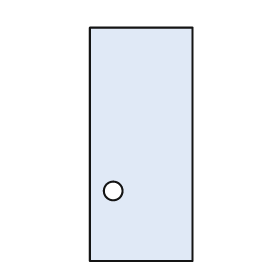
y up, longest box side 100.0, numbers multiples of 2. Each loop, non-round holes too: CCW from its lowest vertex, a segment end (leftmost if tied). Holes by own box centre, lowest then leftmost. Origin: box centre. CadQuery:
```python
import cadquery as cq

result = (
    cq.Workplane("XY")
    .moveTo(-22.0, -50.0)
    .lineTo(22.0, -50.0)
    .lineTo(22.0, 50.0)
    .lineTo(-22.0, 50.0)
    .close()
    .moveTo(-12.0, -20.0)
    .circle(4.0)
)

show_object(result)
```